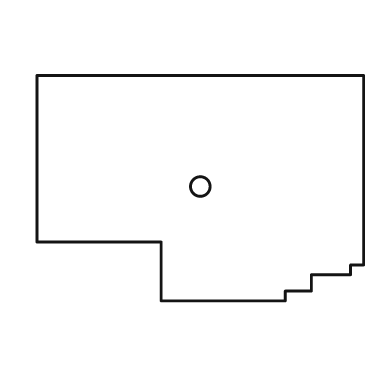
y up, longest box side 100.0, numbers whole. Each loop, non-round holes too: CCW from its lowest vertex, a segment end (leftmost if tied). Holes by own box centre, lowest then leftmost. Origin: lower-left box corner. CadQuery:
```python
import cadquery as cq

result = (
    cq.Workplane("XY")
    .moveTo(38.0, 0.0)
    .lineTo(76.0, 0.0)
    .lineTo(76.0, 3.0)
    .lineTo(84.0, 3.0)
    .lineTo(84.0, 8.0)
    .lineTo(96.0, 8.0)
    .lineTo(96.0, 11.0)
    .lineTo(100.0, 11.0)
    .lineTo(100.0, 69.0)
    .lineTo(0.0, 69.0)
    .lineTo(0.0, 18.0)
    .lineTo(38.0, 18.0)
    .close()
    .moveTo(50.0, 35.0)
    .circle(3.0)
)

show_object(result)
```